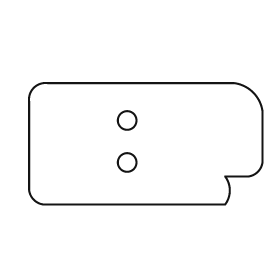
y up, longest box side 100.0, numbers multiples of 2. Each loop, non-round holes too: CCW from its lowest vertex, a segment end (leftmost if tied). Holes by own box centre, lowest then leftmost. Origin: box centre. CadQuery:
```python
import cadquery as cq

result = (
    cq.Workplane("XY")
    .moveTo(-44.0, -26.0)
    .lineTo(34.0, -26.0)
    .threePointArc((36.0, -20.0), (34.0, -14.0))
    .lineTo(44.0, -14.0)
    .threePointArc((48.0, -12.0), (50.0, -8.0))
    .lineTo(50.0, 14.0)
    .threePointArc((46.0, 22.0), (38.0, 26.0))
    .lineTo(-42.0, 26.0)
    .threePointArc((-48.0, 24.0), (-50.0, 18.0))
    .lineTo(-50.0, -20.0)
    .threePointArc((-48.0, -24.0), (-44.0, -26.0))
    .close()
    .moveTo(-8.0, -8.0)
    .circle(4.0)
    .moveTo(-8.0, 10.0)
    .circle(4.0)
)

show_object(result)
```